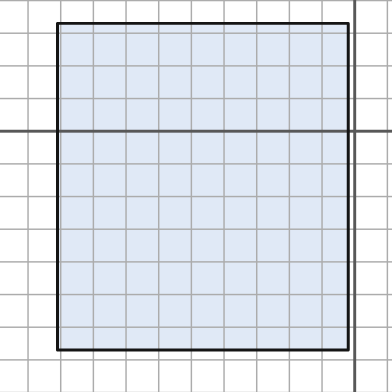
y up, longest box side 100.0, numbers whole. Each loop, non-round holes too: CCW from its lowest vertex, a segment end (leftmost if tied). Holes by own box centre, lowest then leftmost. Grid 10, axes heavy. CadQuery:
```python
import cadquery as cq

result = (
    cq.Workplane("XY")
    .moveTo(-91.0, -67.0)
    .lineTo(-2.0, -67.0)
    .lineTo(-2.0, 33.0)
    .lineTo(-91.0, 33.0)
    .close()
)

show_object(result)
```